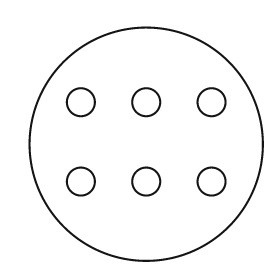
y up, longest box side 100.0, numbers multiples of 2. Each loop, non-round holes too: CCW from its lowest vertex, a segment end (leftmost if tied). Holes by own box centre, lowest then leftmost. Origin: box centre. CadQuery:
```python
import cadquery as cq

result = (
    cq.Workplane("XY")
    .moveTo(0.0, 0.0)
    .circle(50.0)
    .moveTo(-28.0, -16.0)
    .circle(6.0)
    .moveTo(0.0, -16.0)
    .circle(6.0)
    .moveTo(28.0, -16.0)
    .circle(6.0)
    .moveTo(-28.0, 18.0)
    .circle(6.0)
    .moveTo(0.0, 18.0)
    .circle(6.0)
    .moveTo(28.0, 18.0)
    .circle(6.0)
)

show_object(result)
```